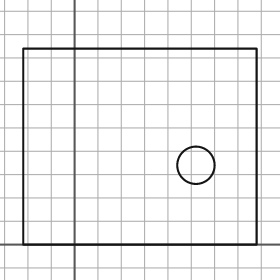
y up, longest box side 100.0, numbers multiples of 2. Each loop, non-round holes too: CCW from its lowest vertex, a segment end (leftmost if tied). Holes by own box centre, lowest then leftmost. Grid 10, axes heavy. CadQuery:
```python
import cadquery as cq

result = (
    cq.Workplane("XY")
    .moveTo(-22.0, 0.0)
    .lineTo(78.0, 0.0)
    .lineTo(78.0, 84.0)
    .lineTo(-22.0, 84.0)
    .close()
    .moveTo(52.0, 34.0)
    .circle(8.0)
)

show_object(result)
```